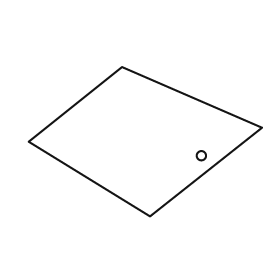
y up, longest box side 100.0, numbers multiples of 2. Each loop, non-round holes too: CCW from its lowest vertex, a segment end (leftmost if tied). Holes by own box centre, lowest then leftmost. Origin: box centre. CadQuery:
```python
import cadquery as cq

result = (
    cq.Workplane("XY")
    .moveTo(2.0, -32.0)
    .lineTo(50.0, 6.0)
    .lineTo(-10.0, 32.0)
    .lineTo(-50.0, 0.0)
    .close()
    .moveTo(24.0, -6.0)
    .circle(2.0)
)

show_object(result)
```